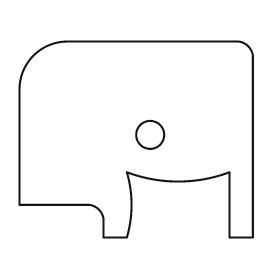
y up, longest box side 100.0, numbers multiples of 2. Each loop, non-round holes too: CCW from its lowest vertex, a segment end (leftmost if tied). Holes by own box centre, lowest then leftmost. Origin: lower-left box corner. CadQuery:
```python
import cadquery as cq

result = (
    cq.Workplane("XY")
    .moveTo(36.0, 0.0)
    .lineTo(46.0, 0.0)
    .threePointArc((48.0, 14.0), (46.0, 28.0))
    .threePointArc((68.0, 24.0), (90.0, 28.0))
    .lineTo(90.0, 0.0)
    .lineTo(100.0, 0.0)
    .lineTo(100.0, 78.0)
    .threePointArc((98.0, 82.0), (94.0, 84.0))
    .lineTo(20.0, 84.0)
    .threePointArc((6.0, 78.0), (0.0, 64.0))
    .lineTo(0.0, 14.0)
    .lineTo(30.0, 14.0)
    .threePointArc((34.0, 12.0), (36.0, 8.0))
    .close()
    .moveTo(56.0, 44.0)
    .circle(6.0)
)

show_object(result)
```